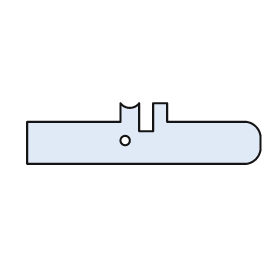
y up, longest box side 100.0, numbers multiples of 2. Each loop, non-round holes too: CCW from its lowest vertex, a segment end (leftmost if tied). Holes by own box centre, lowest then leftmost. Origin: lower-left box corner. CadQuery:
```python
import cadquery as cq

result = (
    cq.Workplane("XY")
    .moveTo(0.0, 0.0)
    .lineTo(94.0, 0.0)
    .threePointArc((98.0, 2.0), (100.0, 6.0))
    .lineTo(100.0, 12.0)
    .threePointArc((98.0, 16.0), (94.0, 18.0))
    .lineTo(60.0, 18.0)
    .lineTo(60.0, 26.0)
    .lineTo(54.0, 26.0)
    .lineTo(54.0, 14.0)
    .lineTo(48.0, 14.0)
    .lineTo(48.0, 26.0)
    .threePointArc((44.0, 24.0), (40.0, 26.0))
    .lineTo(40.0, 18.0)
    .lineTo(0.0, 18.0)
    .close()
    .moveTo(42.0, 10.0)
    .circle(2.0)
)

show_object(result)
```